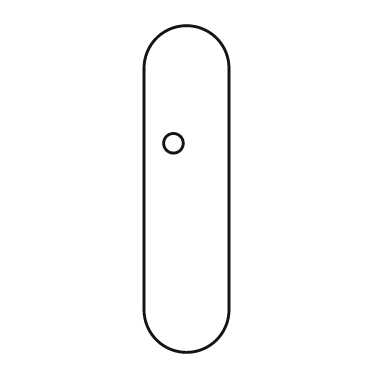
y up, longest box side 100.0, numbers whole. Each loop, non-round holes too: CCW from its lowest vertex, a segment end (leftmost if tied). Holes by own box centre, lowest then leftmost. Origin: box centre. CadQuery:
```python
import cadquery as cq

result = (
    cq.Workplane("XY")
    .moveTo(-13.0, -37.0)
    .threePointArc((0.0, -50.0), (13.0, -37.0))
    .lineTo(13.0, 37.0)
    .threePointArc((0.0, 50.0), (-13.0, 37.0))
    .close()
    .moveTo(-4.0, 14.0)
    .circle(3.0)
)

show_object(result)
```